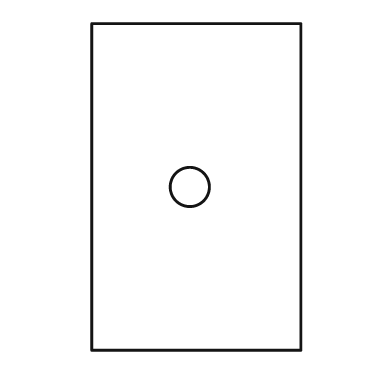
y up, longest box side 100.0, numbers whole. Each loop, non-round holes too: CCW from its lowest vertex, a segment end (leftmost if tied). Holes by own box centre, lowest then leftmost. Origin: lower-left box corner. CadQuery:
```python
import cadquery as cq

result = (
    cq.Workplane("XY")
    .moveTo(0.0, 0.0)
    .lineTo(64.0, 0.0)
    .lineTo(64.0, 100.0)
    .lineTo(0.0, 100.0)
    .close()
    .moveTo(30.0, 50.0)
    .circle(6.0)
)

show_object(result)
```